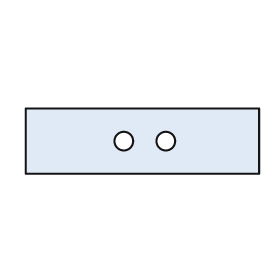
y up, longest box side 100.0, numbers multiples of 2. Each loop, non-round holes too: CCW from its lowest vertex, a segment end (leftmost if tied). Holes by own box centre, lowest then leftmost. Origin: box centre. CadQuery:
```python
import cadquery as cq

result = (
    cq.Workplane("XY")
    .moveTo(-50.0, -14.0)
    .lineTo(50.0, -14.0)
    .lineTo(50.0, 14.0)
    .lineTo(-50.0, 14.0)
    .close()
    .moveTo(-8.0, 0.0)
    .circle(4.0)
    .moveTo(10.0, 0.0)
    .circle(4.0)
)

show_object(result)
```